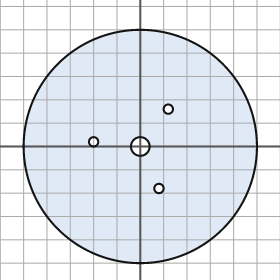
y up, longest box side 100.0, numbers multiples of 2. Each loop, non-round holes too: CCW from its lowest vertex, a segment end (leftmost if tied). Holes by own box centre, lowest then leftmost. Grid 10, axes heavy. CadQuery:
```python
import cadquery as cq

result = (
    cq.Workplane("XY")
    .moveTo(0.0, 0.0)
    .circle(50.0)
    .moveTo(8.0, -18.0)
    .circle(2.0)
    .moveTo(0.0, 0.0)
    .circle(4.0)
    .moveTo(-20.0, 2.0)
    .circle(2.0)
    .moveTo(12.0, 16.0)
    .circle(2.0)
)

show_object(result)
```